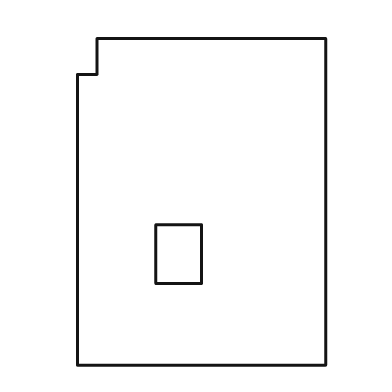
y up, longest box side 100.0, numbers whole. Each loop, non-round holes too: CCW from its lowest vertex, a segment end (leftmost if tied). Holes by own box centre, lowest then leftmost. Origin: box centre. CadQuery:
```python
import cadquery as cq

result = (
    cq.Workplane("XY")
    .moveTo(-38.0, -50.0)
    .lineTo(38.0, -50.0)
    .lineTo(38.0, 50.0)
    .lineTo(-32.0, 50.0)
    .lineTo(-32.0, 39.0)
    .lineTo(-38.0, 39.0)
    .close()
    .moveTo(-14.0, -25.0)
    .lineTo(0.0, -25.0)
    .lineTo(0.0, -7.0)
    .lineTo(-14.0, -7.0)
    .close()
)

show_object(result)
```